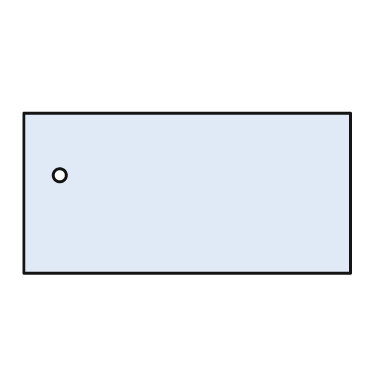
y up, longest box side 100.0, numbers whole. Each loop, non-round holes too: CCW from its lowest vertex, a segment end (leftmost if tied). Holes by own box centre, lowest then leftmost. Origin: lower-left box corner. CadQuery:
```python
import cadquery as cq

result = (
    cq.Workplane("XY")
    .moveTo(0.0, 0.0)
    .lineTo(100.0, 0.0)
    .lineTo(100.0, 49.0)
    .lineTo(0.0, 49.0)
    .close()
    .moveTo(11.0, 30.0)
    .circle(2.0)
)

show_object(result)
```